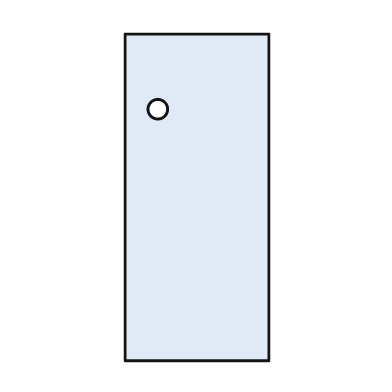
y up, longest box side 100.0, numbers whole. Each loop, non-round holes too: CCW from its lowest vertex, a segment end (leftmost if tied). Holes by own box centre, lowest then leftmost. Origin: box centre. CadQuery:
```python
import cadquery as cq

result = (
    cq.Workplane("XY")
    .moveTo(-22.0, -50.0)
    .lineTo(22.0, -50.0)
    .lineTo(22.0, 50.0)
    .lineTo(-22.0, 50.0)
    .close()
    .moveTo(-12.0, 27.0)
    .circle(3.0)
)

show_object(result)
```